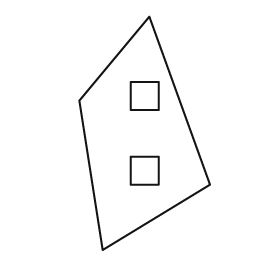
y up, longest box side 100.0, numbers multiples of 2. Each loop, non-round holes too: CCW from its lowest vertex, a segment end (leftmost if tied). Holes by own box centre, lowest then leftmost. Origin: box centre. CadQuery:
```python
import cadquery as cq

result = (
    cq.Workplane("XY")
    .moveTo(-18.0, -50.0)
    .lineTo(28.0, -22.0)
    .lineTo(2.0, 50.0)
    .lineTo(-28.0, 14.0)
    .close()
    .moveTo(-6.0, -22.0)
    .lineTo(6.0, -22.0)
    .lineTo(6.0, -10.0)
    .lineTo(-6.0, -10.0)
    .close()
    .moveTo(-6.0, 10.0)
    .lineTo(6.0, 10.0)
    .lineTo(6.0, 22.0)
    .lineTo(-6.0, 22.0)
    .close()
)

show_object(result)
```